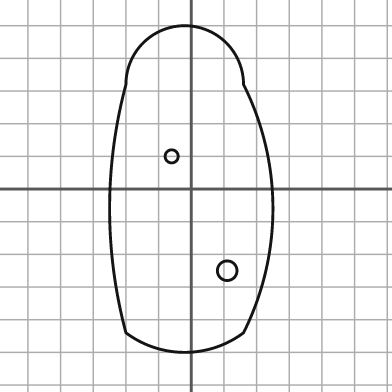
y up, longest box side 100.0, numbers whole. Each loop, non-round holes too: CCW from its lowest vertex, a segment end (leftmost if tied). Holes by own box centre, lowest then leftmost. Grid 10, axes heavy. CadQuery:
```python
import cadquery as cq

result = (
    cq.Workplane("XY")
    .moveTo(-20.0, -44.0)
    .threePointArc((-2.0, -50.0), (16.0, -44.0))
    .threePointArc((25.0, -6.0), (16.0, 32.0))
    .threePointArc((-2.0, 50.0), (-20.0, 32.0))
    .threePointArc((-25.0, -6.0), (-20.0, -44.0))
    .close()
    .moveTo(11.0, -25.0)
    .circle(3.0)
    .moveTo(-6.0, 10.0)
    .circle(2.0)
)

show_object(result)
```